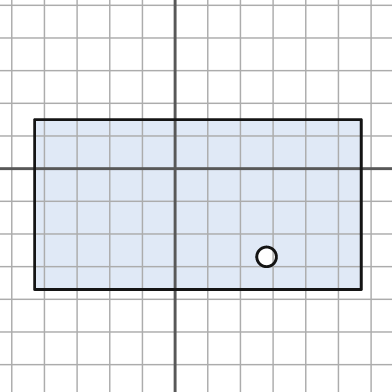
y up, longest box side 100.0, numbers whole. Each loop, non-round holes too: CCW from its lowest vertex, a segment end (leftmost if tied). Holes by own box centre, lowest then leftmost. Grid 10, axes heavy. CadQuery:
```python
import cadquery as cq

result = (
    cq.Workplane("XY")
    .moveTo(-43.0, -37.0)
    .lineTo(57.0, -37.0)
    .lineTo(57.0, 15.0)
    .lineTo(-43.0, 15.0)
    .close()
    .moveTo(28.0, -27.0)
    .circle(3.0)
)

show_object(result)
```